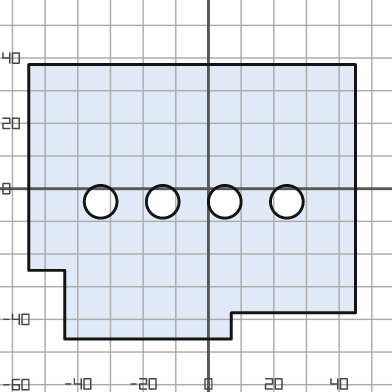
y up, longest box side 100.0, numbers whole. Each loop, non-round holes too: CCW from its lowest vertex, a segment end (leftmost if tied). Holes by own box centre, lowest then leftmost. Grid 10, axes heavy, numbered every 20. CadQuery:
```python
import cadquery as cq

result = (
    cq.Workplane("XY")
    .moveTo(-44.0, -46.0)
    .lineTo(7.0, -46.0)
    .lineTo(7.0, -38.0)
    .lineTo(45.0, -38.0)
    .lineTo(45.0, 38.0)
    .lineTo(-55.0, 38.0)
    .lineTo(-55.0, -25.0)
    .lineTo(-44.0, -25.0)
    .close()
    .moveTo(-33.0, -4.0)
    .circle(5.0)
    .moveTo(-14.0, -4.0)
    .circle(5.0)
    .moveTo(5.0, -4.0)
    .circle(5.0)
    .moveTo(24.0, -4.0)
    .circle(5.0)
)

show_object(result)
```